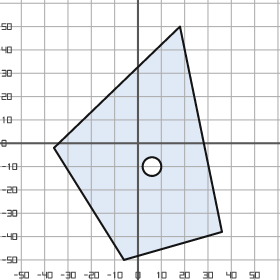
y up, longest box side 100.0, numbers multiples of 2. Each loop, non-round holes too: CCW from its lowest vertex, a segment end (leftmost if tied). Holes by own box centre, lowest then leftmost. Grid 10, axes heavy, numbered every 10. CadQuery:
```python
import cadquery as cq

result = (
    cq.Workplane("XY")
    .moveTo(-6.0, -50.0)
    .lineTo(36.0, -38.0)
    .lineTo(18.0, 50.0)
    .lineTo(-36.0, -2.0)
    .close()
    .moveTo(6.0, -10.0)
    .circle(4.0)
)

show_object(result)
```